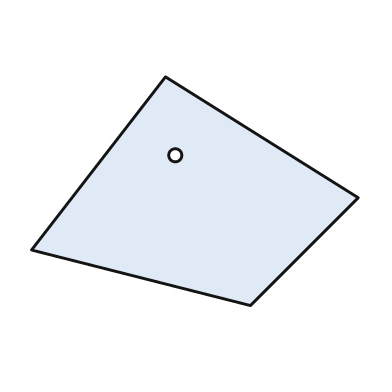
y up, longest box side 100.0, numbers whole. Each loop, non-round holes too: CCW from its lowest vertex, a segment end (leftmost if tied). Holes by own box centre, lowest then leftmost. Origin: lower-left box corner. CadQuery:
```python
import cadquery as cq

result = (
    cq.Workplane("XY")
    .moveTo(67.0, 0.0)
    .lineTo(100.0, 33.0)
    .lineTo(41.0, 70.0)
    .lineTo(0.0, 17.0)
    .close()
    .moveTo(44.0, 46.0)
    .circle(2.0)
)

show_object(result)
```